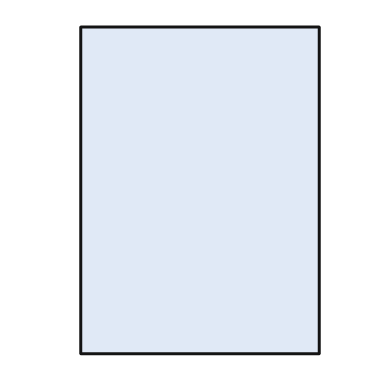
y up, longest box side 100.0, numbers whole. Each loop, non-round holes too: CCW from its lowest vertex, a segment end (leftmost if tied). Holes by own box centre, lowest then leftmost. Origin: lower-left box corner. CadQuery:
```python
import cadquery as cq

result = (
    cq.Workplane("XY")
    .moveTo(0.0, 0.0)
    .lineTo(73.0, 0.0)
    .lineTo(73.0, 100.0)
    .lineTo(0.0, 100.0)
    .close()
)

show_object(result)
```